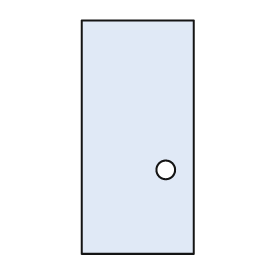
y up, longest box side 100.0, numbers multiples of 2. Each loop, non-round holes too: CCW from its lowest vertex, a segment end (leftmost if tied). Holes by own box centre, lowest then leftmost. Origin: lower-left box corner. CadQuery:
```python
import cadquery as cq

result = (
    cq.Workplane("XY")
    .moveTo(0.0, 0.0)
    .lineTo(48.0, 0.0)
    .lineTo(48.0, 100.0)
    .lineTo(0.0, 100.0)
    .close()
    .moveTo(36.0, 36.0)
    .circle(4.0)
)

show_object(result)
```